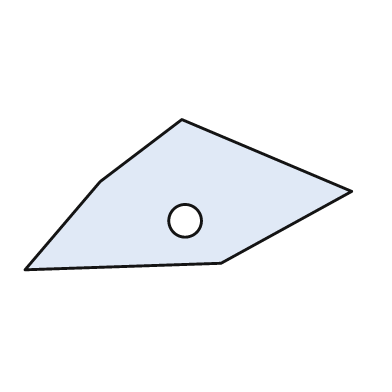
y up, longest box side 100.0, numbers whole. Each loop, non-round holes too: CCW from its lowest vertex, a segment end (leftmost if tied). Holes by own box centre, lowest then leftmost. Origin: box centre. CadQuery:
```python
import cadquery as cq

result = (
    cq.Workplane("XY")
    .moveTo(-50.0, -23.0)
    .lineTo(10.0, -21.0)
    .lineTo(50.0, 1.0)
    .lineTo(-2.0, 23.0)
    .lineTo(-27.0, 4.0)
    .close()
    .moveTo(-1.0, -8.0)
    .circle(5.0)
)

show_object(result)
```